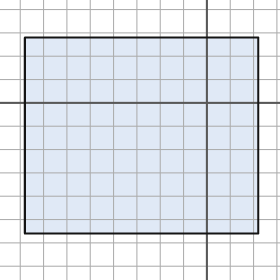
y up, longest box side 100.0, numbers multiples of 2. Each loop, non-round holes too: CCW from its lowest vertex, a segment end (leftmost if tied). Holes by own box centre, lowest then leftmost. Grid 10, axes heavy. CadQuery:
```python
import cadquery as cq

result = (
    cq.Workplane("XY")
    .moveTo(-78.0, -56.0)
    .lineTo(22.0, -56.0)
    .lineTo(22.0, 28.0)
    .lineTo(-78.0, 28.0)
    .close()
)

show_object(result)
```